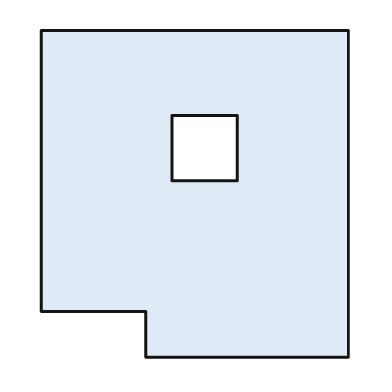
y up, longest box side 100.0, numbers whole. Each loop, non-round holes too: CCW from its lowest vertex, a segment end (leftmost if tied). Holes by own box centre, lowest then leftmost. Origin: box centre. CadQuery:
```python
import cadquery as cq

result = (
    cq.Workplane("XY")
    .moveTo(-15.0, -50.0)
    .lineTo(47.0, -50.0)
    .lineTo(47.0, 50.0)
    .lineTo(-47.0, 50.0)
    .lineTo(-47.0, -36.0)
    .lineTo(-15.0, -36.0)
    .close()
    .moveTo(-7.0, 4.0)
    .lineTo(13.0, 4.0)
    .lineTo(13.0, 24.0)
    .lineTo(-7.0, 24.0)
    .close()
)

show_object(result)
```